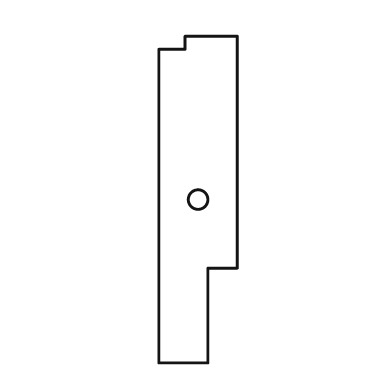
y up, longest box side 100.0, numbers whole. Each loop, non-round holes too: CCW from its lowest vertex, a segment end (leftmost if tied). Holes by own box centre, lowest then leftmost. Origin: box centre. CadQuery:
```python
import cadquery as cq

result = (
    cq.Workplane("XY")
    .moveTo(-12.0, -50.0)
    .lineTo(3.0, -50.0)
    .lineTo(3.0, -21.0)
    .lineTo(12.0, -21.0)
    .lineTo(12.0, 50.0)
    .lineTo(-4.0, 50.0)
    .lineTo(-4.0, 46.0)
    .lineTo(-12.0, 46.0)
    .close()
    .moveTo(0.0, 0.0)
    .circle(3.0)
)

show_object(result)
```